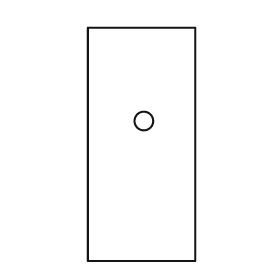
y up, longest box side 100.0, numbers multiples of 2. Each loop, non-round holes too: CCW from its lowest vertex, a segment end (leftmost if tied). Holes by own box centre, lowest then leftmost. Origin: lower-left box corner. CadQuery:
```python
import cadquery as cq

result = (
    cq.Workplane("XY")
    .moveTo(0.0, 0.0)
    .lineTo(46.0, 0.0)
    .lineTo(46.0, 100.0)
    .lineTo(0.0, 100.0)
    .close()
    .moveTo(24.0, 60.0)
    .circle(4.0)
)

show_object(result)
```